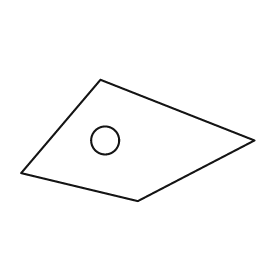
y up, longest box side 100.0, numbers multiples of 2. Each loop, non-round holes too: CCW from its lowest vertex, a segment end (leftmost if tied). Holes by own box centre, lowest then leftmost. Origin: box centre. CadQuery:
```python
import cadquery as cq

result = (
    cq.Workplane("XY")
    .moveTo(0.0, -26.0)
    .lineTo(50.0, 0.0)
    .lineTo(-16.0, 26.0)
    .lineTo(-50.0, -14.0)
    .close()
    .moveTo(-14.0, 0.0)
    .circle(6.0)
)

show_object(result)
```